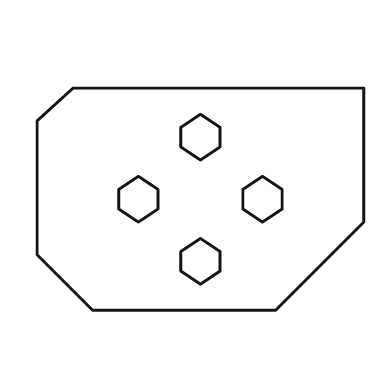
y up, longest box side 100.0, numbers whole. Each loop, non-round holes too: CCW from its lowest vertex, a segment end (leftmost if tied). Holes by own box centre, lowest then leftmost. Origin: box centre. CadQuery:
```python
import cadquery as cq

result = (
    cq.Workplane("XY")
    .moveTo(-33.0, -34.0)
    .lineTo(23.0, -34.0)
    .lineTo(50.0, -7.0)
    .lineTo(50.0, 34.0)
    .lineTo(-39.0, 34.0)
    .lineTo(-50.0, 24.0)
    .lineTo(-50.0, -17.0)
    .close()
    .moveTo(0.0, -26.0)
    .lineTo(6.0, -22.0)
    .lineTo(6.0, -16.0)
    .lineTo(0.0, -12.0)
    .lineTo(-6.0, -16.0)
    .lineTo(-6.0, -22.0)
    .close()
    .moveTo(-19.0, -7.0)
    .lineTo(-13.0, -3.0)
    .lineTo(-13.0, 3.0)
    .lineTo(-19.0, 7.0)
    .lineTo(-25.0, 3.0)
    .lineTo(-25.0, -3.0)
    .close()
    .moveTo(19.0, -7.0)
    .lineTo(25.0, -3.0)
    .lineTo(25.0, 3.0)
    .lineTo(19.0, 7.0)
    .lineTo(13.0, 3.0)
    .lineTo(13.0, -3.0)
    .close()
    .moveTo(0.0, 12.0)
    .lineTo(6.0, 16.0)
    .lineTo(6.0, 22.0)
    .lineTo(0.0, 26.0)
    .lineTo(-6.0, 22.0)
    .lineTo(-6.0, 16.0)
    .close()
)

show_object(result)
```